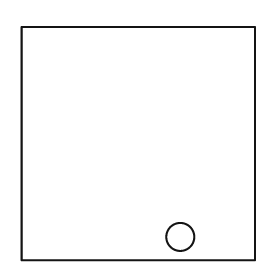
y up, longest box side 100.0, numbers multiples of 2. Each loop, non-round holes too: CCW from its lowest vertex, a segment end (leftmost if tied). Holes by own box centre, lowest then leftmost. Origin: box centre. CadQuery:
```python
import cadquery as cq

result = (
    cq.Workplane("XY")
    .moveTo(-50.0, -50.0)
    .lineTo(50.0, -50.0)
    .lineTo(50.0, 50.0)
    .lineTo(-50.0, 50.0)
    .close()
    .moveTo(18.0, -40.0)
    .circle(6.0)
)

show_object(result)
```